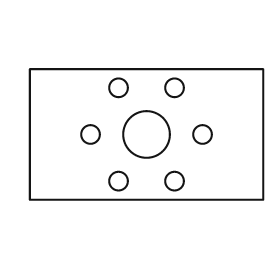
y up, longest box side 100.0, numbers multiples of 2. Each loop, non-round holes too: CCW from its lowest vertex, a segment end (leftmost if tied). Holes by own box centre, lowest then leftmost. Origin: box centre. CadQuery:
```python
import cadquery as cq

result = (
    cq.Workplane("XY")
    .moveTo(-50.0, -28.0)
    .lineTo(50.0, -28.0)
    .lineTo(50.0, 28.0)
    .lineTo(-50.0, 28.0)
    .close()
    .moveTo(-12.0, -20.0)
    .circle(4.0)
    .moveTo(12.0, -20.0)
    .circle(4.0)
    .moveTo(-24.0, 0.0)
    .circle(4.0)
    .moveTo(0.0, 0.0)
    .circle(10.0)
    .moveTo(24.0, 0.0)
    .circle(4.0)
    .moveTo(-12.0, 20.0)
    .circle(4.0)
    .moveTo(12.0, 20.0)
    .circle(4.0)
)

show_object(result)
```